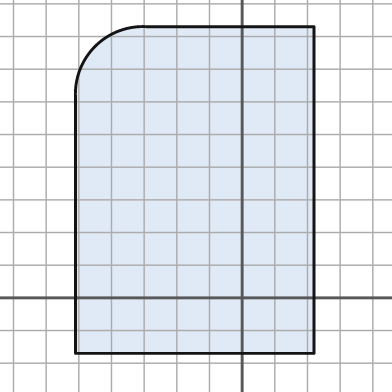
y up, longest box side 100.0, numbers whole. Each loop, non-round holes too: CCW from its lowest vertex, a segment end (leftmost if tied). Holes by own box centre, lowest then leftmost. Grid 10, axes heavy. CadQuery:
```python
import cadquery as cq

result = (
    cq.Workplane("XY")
    .moveTo(-51.0, -17.0)
    .lineTo(22.0, -17.0)
    .lineTo(22.0, 83.0)
    .lineTo(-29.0, 83.0)
    .threePointArc((-45.0, 77.0), (-51.0, 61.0))
    .close()
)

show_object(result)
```